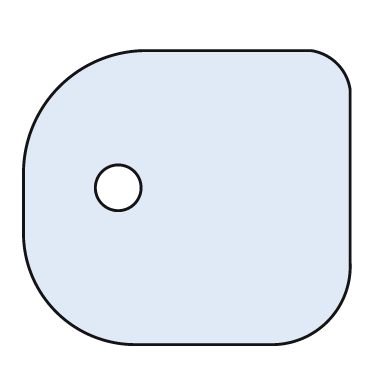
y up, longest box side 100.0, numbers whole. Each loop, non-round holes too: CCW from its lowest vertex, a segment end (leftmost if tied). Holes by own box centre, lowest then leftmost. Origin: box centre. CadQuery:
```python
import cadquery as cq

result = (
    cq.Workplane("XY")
    .moveTo(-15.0, -45.0)
    .lineTo(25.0, -45.0)
    .threePointArc((43.0, -38.0), (50.0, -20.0))
    .lineTo(50.0, 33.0)
    .threePointArc((46.0, 41.0), (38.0, 45.0))
    .lineTo(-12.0, 45.0)
    .threePointArc((-39.0, 34.0), (-50.0, 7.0))
    .lineTo(-50.0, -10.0)
    .threePointArc((-40.0, -35.0), (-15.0, -45.0))
    .close()
    .moveTo(-21.0, 3.0)
    .circle(7.0)
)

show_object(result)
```